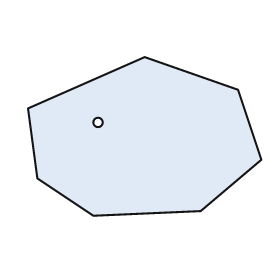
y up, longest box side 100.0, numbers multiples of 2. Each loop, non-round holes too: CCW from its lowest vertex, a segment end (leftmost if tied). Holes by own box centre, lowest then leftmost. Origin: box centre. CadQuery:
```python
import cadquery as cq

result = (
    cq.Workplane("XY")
    .moveTo(-22.0, -34.0)
    .lineTo(24.0, -32.0)
    .lineTo(50.0, -10.0)
    .lineTo(40.0, 20.0)
    .lineTo(0.0, 34.0)
    .lineTo(-50.0, 12.0)
    .lineTo(-46.0, -18.0)
    .close()
    .moveTo(-20.0, 6.0)
    .circle(2.0)
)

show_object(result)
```